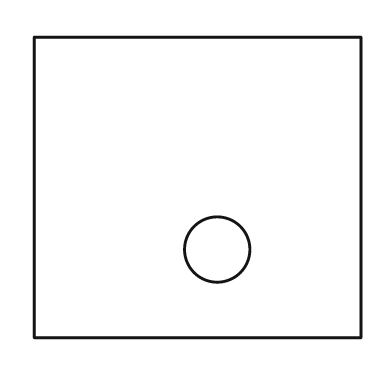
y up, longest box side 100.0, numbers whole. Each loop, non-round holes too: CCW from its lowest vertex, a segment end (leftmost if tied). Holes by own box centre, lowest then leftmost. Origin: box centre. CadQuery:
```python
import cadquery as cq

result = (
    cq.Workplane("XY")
    .moveTo(-50.0, -46.0)
    .lineTo(50.0, -46.0)
    .lineTo(50.0, 46.0)
    .lineTo(-50.0, 46.0)
    .close()
    .moveTo(6.0, -19.0)
    .circle(10.0)
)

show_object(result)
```